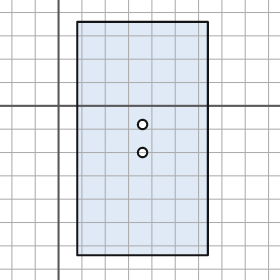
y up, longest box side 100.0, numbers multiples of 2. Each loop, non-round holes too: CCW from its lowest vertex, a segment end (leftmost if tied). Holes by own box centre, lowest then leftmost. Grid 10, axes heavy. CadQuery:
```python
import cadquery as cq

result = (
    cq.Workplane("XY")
    .moveTo(8.0, -64.0)
    .lineTo(64.0, -64.0)
    .lineTo(64.0, 36.0)
    .lineTo(8.0, 36.0)
    .close()
    .moveTo(36.0, -20.0)
    .circle(2.0)
    .moveTo(36.0, -8.0)
    .circle(2.0)
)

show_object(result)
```